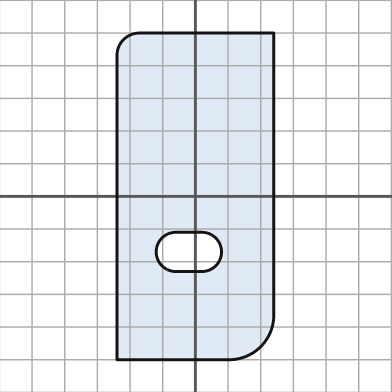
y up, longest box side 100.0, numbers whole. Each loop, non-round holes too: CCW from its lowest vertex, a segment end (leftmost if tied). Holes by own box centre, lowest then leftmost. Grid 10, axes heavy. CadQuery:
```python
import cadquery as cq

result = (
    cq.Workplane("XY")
    .moveTo(-24.0, -50.0)
    .lineTo(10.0, -50.0)
    .threePointArc((20.0, -46.0), (24.0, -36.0))
    .lineTo(24.0, 50.0)
    .lineTo(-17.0, 50.0)
    .threePointArc((-22.0, 48.0), (-24.0, 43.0))
    .close()
    .moveTo(-6.0, -23.0)
    .lineTo(2.0, -23.0)
    .threePointArc((8.0, -17.0), (2.0, -11.0))
    .lineTo(-6.0, -11.0)
    .threePointArc((-12.0, -17.0), (-6.0, -23.0))
    .close()
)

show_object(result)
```